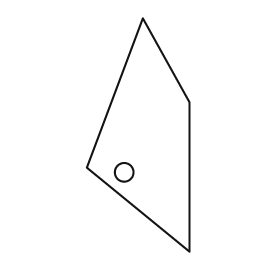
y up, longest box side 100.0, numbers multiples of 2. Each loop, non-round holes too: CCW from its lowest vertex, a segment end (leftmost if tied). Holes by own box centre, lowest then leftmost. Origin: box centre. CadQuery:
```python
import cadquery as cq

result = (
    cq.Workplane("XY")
    .moveTo(22.0, -50.0)
    .lineTo(22.0, 14.0)
    .lineTo(2.0, 50.0)
    .lineTo(-22.0, -14.0)
    .close()
    .moveTo(-6.0, -16.0)
    .circle(4.0)
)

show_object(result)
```